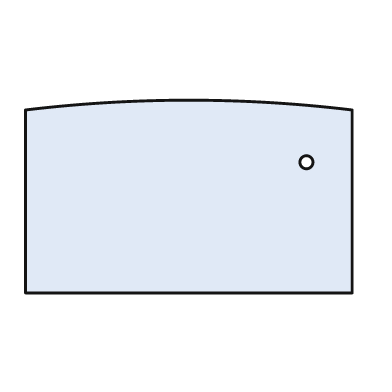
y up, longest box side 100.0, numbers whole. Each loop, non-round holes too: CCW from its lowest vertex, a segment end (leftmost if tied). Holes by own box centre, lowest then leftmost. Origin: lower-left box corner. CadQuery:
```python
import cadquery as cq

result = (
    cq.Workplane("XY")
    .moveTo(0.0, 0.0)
    .lineTo(100.0, 0.0)
    .lineTo(100.0, 56.0)
    .threePointArc((50.0, 59.0), (0.0, 56.0))
    .close()
    .moveTo(86.0, 40.0)
    .circle(2.0)
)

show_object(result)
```